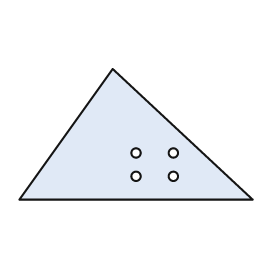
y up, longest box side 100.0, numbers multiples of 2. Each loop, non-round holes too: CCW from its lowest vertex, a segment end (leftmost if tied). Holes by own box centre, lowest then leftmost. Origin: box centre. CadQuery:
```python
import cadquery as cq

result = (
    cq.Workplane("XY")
    .moveTo(-50.0, -28.0)
    .lineTo(50.0, -28.0)
    .lineTo(-10.0, 28.0)
    .close()
    .moveTo(0.0, -18.0)
    .circle(2.0)
    .moveTo(16.0, -18.0)
    .circle(2.0)
    .moveTo(0.0, -8.0)
    .circle(2.0)
    .moveTo(16.0, -8.0)
    .circle(2.0)
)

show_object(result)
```